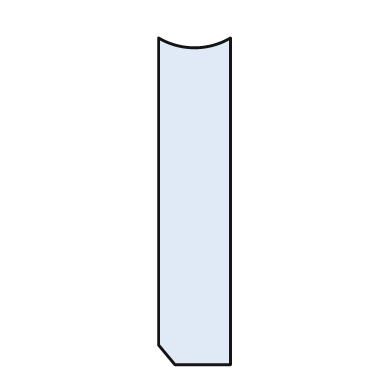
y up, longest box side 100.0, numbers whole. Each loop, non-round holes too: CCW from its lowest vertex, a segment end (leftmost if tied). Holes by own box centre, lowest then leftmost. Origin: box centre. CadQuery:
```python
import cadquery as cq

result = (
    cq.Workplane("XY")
    .moveTo(-6.0, -50.0)
    .lineTo(11.0, -50.0)
    .lineTo(11.0, 50.0)
    .threePointArc((0.0, 47.0), (-11.0, 50.0))
    .lineTo(-11.0, -44.0)
    .close()
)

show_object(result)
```